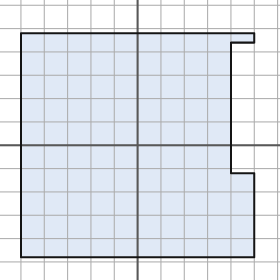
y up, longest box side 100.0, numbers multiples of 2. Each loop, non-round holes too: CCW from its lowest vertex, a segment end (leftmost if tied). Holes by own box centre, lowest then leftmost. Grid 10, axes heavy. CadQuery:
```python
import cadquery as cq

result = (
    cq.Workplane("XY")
    .moveTo(-50.0, -48.0)
    .lineTo(50.0, -48.0)
    .lineTo(50.0, -12.0)
    .lineTo(40.0, -12.0)
    .lineTo(40.0, 44.0)
    .lineTo(50.0, 44.0)
    .lineTo(50.0, 48.0)
    .lineTo(-50.0, 48.0)
    .close()
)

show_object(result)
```